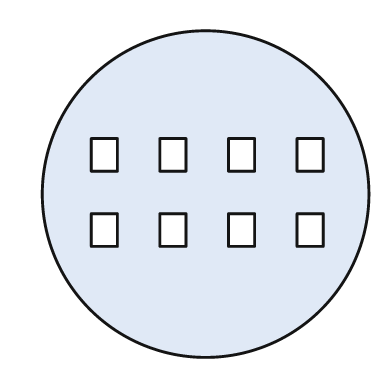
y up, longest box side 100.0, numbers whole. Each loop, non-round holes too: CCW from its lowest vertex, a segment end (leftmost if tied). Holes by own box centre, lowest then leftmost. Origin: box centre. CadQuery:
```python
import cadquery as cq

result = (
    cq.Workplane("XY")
    .moveTo(0.0, 0.0)
    .circle(50.0)
    .moveTo(-35.0, -16.0)
    .lineTo(-27.0, -16.0)
    .lineTo(-27.0, -6.0)
    .lineTo(-35.0, -6.0)
    .close()
    .moveTo(-14.0, -16.0)
    .lineTo(-6.0, -16.0)
    .lineTo(-6.0, -6.0)
    .lineTo(-14.0, -6.0)
    .close()
    .moveTo(7.0, -16.0)
    .lineTo(15.0, -16.0)
    .lineTo(15.0, -6.0)
    .lineTo(7.0, -6.0)
    .close()
    .moveTo(28.0, -16.0)
    .lineTo(36.0, -16.0)
    .lineTo(36.0, -6.0)
    .lineTo(28.0, -6.0)
    .close()
    .moveTo(-35.0, 7.0)
    .lineTo(-27.0, 7.0)
    .lineTo(-27.0, 17.0)
    .lineTo(-35.0, 17.0)
    .close()
    .moveTo(-14.0, 7.0)
    .lineTo(-6.0, 7.0)
    .lineTo(-6.0, 17.0)
    .lineTo(-14.0, 17.0)
    .close()
    .moveTo(7.0, 7.0)
    .lineTo(15.0, 7.0)
    .lineTo(15.0, 17.0)
    .lineTo(7.0, 17.0)
    .close()
    .moveTo(28.0, 7.0)
    .lineTo(36.0, 7.0)
    .lineTo(36.0, 17.0)
    .lineTo(28.0, 17.0)
    .close()
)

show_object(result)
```